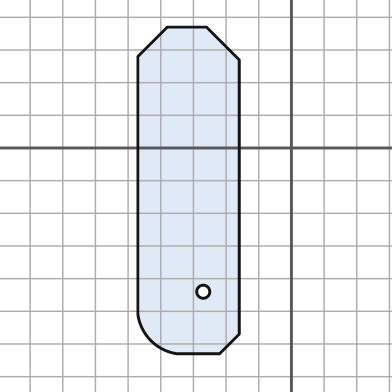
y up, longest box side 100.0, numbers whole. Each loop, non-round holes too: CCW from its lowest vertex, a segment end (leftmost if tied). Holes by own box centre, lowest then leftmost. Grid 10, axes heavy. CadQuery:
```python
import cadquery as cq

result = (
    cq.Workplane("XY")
    .moveTo(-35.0, -63.0)
    .lineTo(-22.0, -63.0)
    .lineTo(-16.0, -57.0)
    .lineTo(-16.0, 27.0)
    .lineTo(-26.0, 37.0)
    .lineTo(-38.0, 37.0)
    .lineTo(-47.0, 28.0)
    .lineTo(-47.0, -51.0)
    .threePointArc((-43.0, -59.0), (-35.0, -63.0))
    .close()
    .moveTo(-27.0, -44.0)
    .circle(2.0)
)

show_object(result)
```